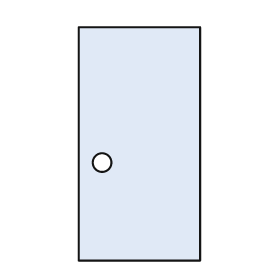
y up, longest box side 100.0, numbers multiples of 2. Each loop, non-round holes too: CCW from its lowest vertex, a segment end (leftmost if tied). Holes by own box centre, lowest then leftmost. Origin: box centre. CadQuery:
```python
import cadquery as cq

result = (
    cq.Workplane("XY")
    .moveTo(-26.0, -50.0)
    .lineTo(26.0, -50.0)
    .lineTo(26.0, 50.0)
    .lineTo(-26.0, 50.0)
    .close()
    .moveTo(-16.0, -8.0)
    .circle(4.0)
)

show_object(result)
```